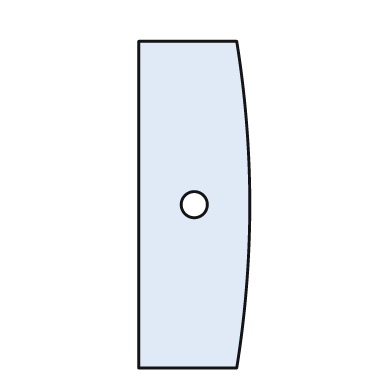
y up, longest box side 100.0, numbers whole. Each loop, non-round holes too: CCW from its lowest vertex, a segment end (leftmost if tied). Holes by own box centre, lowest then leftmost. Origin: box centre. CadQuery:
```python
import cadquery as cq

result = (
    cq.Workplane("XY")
    .moveTo(-17.0, -50.0)
    .lineTo(13.0, -50.0)
    .threePointArc((17.0, 0.0), (13.0, 50.0))
    .lineTo(-17.0, 50.0)
    .close()
    .moveTo(0.0, 0.0)
    .circle(4.0)
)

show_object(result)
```